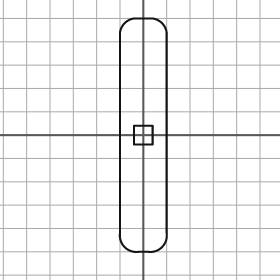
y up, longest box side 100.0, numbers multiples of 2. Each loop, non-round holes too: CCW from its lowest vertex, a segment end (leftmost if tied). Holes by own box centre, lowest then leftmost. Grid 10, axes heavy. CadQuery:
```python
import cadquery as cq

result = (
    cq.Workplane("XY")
    .moveTo(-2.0, -50.0)
    .lineTo(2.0, -50.0)
    .threePointArc((8.0, -48.0), (10.0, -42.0))
    .lineTo(10.0, 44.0)
    .threePointArc((8.0, 48.0), (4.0, 50.0))
    .lineTo(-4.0, 50.0)
    .threePointArc((-8.0, 48.0), (-10.0, 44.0))
    .lineTo(-10.0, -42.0)
    .threePointArc((-8.0, -48.0), (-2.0, -50.0))
    .close()
    .moveTo(-4.0, -4.0)
    .lineTo(4.0, -4.0)
    .lineTo(4.0, 4.0)
    .lineTo(-4.0, 4.0)
    .close()
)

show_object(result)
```